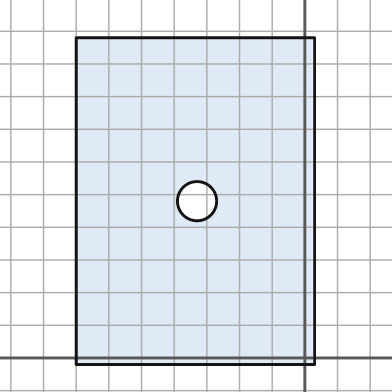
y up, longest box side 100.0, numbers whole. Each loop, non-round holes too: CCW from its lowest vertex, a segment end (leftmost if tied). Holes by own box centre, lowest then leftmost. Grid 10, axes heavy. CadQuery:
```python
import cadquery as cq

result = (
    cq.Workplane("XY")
    .moveTo(-70.0, -2.0)
    .lineTo(3.0, -2.0)
    .lineTo(3.0, 98.0)
    .lineTo(-70.0, 98.0)
    .close()
    .moveTo(-33.0, 48.0)
    .circle(6.0)
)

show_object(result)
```